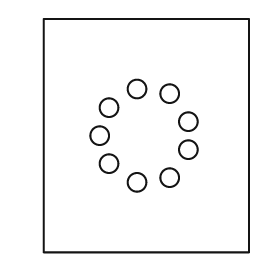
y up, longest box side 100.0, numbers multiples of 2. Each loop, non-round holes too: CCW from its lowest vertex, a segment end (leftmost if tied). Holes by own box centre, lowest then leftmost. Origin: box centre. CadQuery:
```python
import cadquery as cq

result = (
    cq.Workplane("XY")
    .moveTo(-44.0, -50.0)
    .lineTo(44.0, -50.0)
    .lineTo(44.0, 50.0)
    .lineTo(-44.0, 50.0)
    .close()
    .moveTo(-4.0, -20.0)
    .circle(4.0)
    .moveTo(10.0, -18.0)
    .circle(4.0)
    .moveTo(-16.0, -12.0)
    .circle(4.0)
    .moveTo(18.0, -6.0)
    .circle(4.0)
    .moveTo(-20.0, 0.0)
    .circle(4.0)
    .moveTo(18.0, 6.0)
    .circle(4.0)
    .moveTo(-16.0, 12.0)
    .circle(4.0)
    .moveTo(10.0, 18.0)
    .circle(4.0)
    .moveTo(-4.0, 20.0)
    .circle(4.0)
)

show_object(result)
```